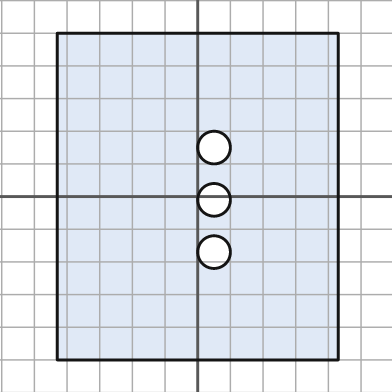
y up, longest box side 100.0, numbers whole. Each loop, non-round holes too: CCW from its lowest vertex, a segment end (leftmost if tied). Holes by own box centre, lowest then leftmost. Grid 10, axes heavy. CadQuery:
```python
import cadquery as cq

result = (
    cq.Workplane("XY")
    .moveTo(-43.0, -50.0)
    .lineTo(43.0, -50.0)
    .lineTo(43.0, 50.0)
    .lineTo(-43.0, 50.0)
    .close()
    .moveTo(5.0, -17.0)
    .circle(5.0)
    .moveTo(5.0, -1.0)
    .circle(5.0)
    .moveTo(5.0, 15.0)
    .circle(5.0)
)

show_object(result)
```